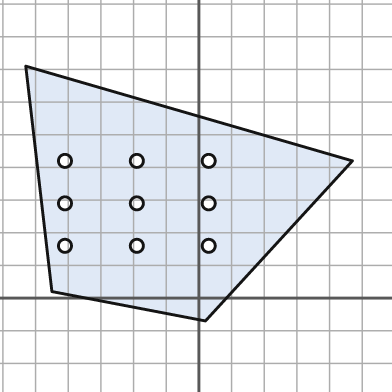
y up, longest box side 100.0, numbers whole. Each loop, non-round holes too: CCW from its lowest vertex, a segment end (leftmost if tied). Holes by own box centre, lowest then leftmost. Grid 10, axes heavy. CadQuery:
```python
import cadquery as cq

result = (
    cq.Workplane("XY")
    .moveTo(2.0, -7.0)
    .lineTo(47.0, 42.0)
    .lineTo(-53.0, 71.0)
    .lineTo(-45.0, 2.0)
    .close()
    .moveTo(-41.0, 16.0)
    .circle(2.0)
    .moveTo(-19.0, 16.0)
    .circle(2.0)
    .moveTo(3.0, 16.0)
    .circle(2.0)
    .moveTo(-41.0, 29.0)
    .circle(2.0)
    .moveTo(-19.0, 29.0)
    .circle(2.0)
    .moveTo(3.0, 29.0)
    .circle(2.0)
    .moveTo(-41.0, 42.0)
    .circle(2.0)
    .moveTo(-19.0, 42.0)
    .circle(2.0)
    .moveTo(3.0, 42.0)
    .circle(2.0)
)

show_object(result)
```